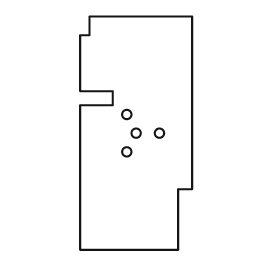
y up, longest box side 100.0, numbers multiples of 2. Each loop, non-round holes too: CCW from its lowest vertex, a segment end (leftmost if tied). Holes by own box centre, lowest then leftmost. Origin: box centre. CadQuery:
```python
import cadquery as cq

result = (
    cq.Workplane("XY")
    .moveTo(-24.0, -50.0)
    .lineTo(18.0, -50.0)
    .lineTo(18.0, -24.0)
    .lineTo(24.0, -24.0)
    .lineTo(24.0, 50.0)
    .lineTo(-20.0, 50.0)
    .lineTo(-20.0, 42.0)
    .lineTo(-24.0, 42.0)
    .lineTo(-24.0, 18.0)
    .lineTo(-10.0, 18.0)
    .lineTo(-10.0, 12.0)
    .lineTo(-24.0, 12.0)
    .close()
    .moveTo(-4.0, -8.0)
    .circle(2.0)
    .moveTo(0.0, 0.0)
    .circle(2.0)
    .moveTo(10.0, 0.0)
    .circle(2.0)
    .moveTo(-4.0, 8.0)
    .circle(2.0)
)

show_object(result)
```